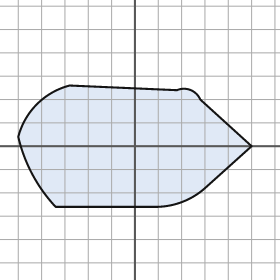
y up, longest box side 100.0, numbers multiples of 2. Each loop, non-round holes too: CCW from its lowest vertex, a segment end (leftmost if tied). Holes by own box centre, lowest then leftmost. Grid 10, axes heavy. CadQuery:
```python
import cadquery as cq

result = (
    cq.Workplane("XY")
    .moveTo(-34.0, -26.0)
    .lineTo(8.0, -26.0)
    .threePointArc((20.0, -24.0), (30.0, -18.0))
    .lineTo(50.0, 0.0)
    .lineTo(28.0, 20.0)
    .threePointArc((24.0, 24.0), (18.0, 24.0))
    .lineTo(-28.0, 26.0)
    .threePointArc((-42.0, 18.0), (-50.0, 4.0))
    .threePointArc((-44.0, -12.0), (-34.0, -26.0))
    .close()
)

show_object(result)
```